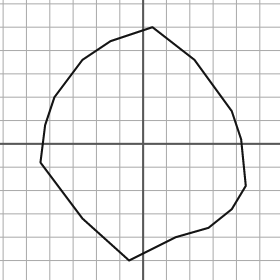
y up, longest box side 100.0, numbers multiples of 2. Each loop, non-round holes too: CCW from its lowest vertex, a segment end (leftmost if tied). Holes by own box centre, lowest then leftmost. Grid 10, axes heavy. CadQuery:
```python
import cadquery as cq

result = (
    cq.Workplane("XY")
    .moveTo(-6.0, -50.0)
    .lineTo(14.0, -40.0)
    .lineTo(28.0, -36.0)
    .lineTo(38.0, -28.0)
    .lineTo(44.0, -18.0)
    .lineTo(42.0, 2.0)
    .lineTo(38.0, 14.0)
    .lineTo(22.0, 36.0)
    .lineTo(4.0, 50.0)
    .lineTo(-14.0, 44.0)
    .lineTo(-26.0, 36.0)
    .lineTo(-38.0, 20.0)
    .lineTo(-42.0, 8.0)
    .lineTo(-44.0, -8.0)
    .lineTo(-26.0, -32.0)
    .close()
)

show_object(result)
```